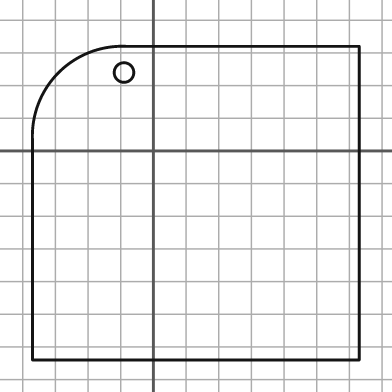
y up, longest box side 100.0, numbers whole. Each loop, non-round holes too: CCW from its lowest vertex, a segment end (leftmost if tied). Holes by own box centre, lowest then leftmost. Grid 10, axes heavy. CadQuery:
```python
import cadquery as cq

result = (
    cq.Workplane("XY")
    .moveTo(-37.0, -64.0)
    .lineTo(63.0, -64.0)
    .lineTo(63.0, 32.0)
    .lineTo(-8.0, 32.0)
    .threePointArc((-29.0, 24.0), (-37.0, 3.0))
    .close()
    .moveTo(-9.0, 24.0)
    .circle(3.0)
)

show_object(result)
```